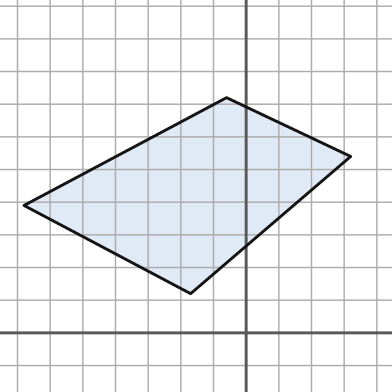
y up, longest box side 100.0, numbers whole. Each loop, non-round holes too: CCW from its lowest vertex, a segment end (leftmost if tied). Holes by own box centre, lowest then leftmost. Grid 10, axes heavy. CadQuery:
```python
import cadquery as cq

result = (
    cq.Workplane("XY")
    .moveTo(-17.0, 12.0)
    .lineTo(32.0, 54.0)
    .lineTo(-6.0, 72.0)
    .lineTo(-68.0, 39.0)
    .close()
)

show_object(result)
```